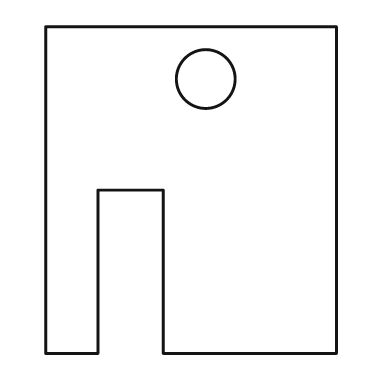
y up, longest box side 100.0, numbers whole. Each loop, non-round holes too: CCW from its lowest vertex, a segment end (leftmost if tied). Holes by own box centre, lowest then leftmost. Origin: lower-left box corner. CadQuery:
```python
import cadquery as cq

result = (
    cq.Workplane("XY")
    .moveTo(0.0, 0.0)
    .lineTo(16.0, 0.0)
    .lineTo(16.0, 50.0)
    .lineTo(36.0, 50.0)
    .lineTo(36.0, 0.0)
    .lineTo(89.0, 0.0)
    .lineTo(89.0, 100.0)
    .lineTo(0.0, 100.0)
    .close()
    .moveTo(49.0, 84.0)
    .circle(9.0)
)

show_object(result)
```